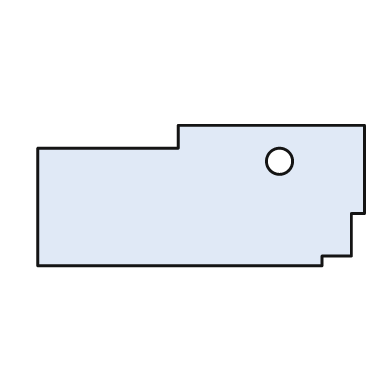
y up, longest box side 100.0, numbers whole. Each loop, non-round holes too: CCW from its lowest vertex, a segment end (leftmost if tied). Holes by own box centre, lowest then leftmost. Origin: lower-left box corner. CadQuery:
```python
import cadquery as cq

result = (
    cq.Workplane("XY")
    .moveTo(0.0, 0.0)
    .lineTo(87.0, 0.0)
    .lineTo(87.0, 3.0)
    .lineTo(96.0, 3.0)
    .lineTo(96.0, 16.0)
    .lineTo(100.0, 16.0)
    .lineTo(100.0, 43.0)
    .lineTo(43.0, 43.0)
    .lineTo(43.0, 36.0)
    .lineTo(0.0, 36.0)
    .close()
    .moveTo(74.0, 32.0)
    .circle(4.0)
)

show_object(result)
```